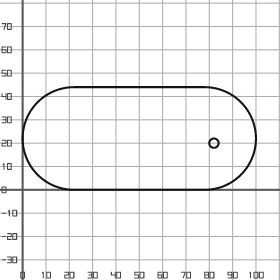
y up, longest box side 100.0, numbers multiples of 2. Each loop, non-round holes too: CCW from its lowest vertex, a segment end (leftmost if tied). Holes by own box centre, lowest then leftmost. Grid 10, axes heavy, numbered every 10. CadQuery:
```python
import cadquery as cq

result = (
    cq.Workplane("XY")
    .moveTo(22.0, 0.0)
    .lineTo(78.0, 0.0)
    .threePointArc((100.0, 22.0), (78.0, 44.0))
    .lineTo(22.0, 44.0)
    .threePointArc((0.0, 22.0), (22.0, 0.0))
    .close()
    .moveTo(82.0, 20.0)
    .circle(2.0)
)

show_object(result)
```